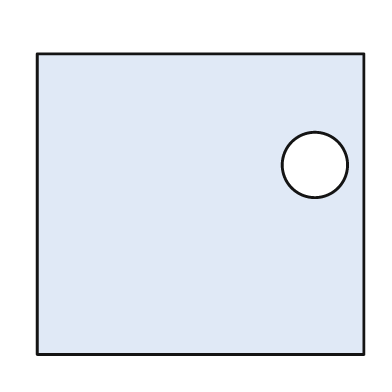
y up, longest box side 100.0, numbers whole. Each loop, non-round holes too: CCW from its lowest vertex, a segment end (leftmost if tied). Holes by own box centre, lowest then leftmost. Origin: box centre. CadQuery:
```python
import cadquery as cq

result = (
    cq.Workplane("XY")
    .moveTo(-50.0, -46.0)
    .lineTo(50.0, -46.0)
    .lineTo(50.0, 46.0)
    .lineTo(-50.0, 46.0)
    .close()
    .moveTo(35.0, 12.0)
    .circle(10.0)
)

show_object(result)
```